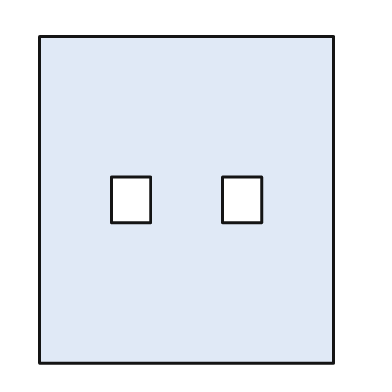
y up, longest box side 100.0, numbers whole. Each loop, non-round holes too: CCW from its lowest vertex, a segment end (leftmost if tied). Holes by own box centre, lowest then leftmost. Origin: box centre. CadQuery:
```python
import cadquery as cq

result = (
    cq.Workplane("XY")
    .moveTo(-45.0, -50.0)
    .lineTo(45.0, -50.0)
    .lineTo(45.0, 50.0)
    .lineTo(-45.0, 50.0)
    .close()
    .moveTo(-23.0, -7.0)
    .lineTo(-11.0, -7.0)
    .lineTo(-11.0, 7.0)
    .lineTo(-23.0, 7.0)
    .close()
    .moveTo(11.0, -7.0)
    .lineTo(23.0, -7.0)
    .lineTo(23.0, 7.0)
    .lineTo(11.0, 7.0)
    .close()
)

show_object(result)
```